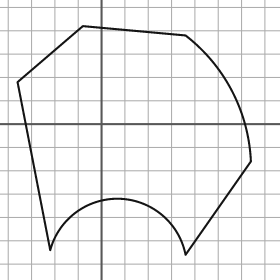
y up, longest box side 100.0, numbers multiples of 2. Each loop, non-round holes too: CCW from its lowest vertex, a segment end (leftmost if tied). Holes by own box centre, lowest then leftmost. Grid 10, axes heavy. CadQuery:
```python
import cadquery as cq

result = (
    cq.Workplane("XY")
    .moveTo(36.0, -56.0)
    .lineTo(64.0, -16.0)
    .threePointArc((56.0, 14.0), (36.0, 38.0))
    .lineTo(-8.0, 42.0)
    .lineTo(-36.0, 18.0)
    .lineTo(-22.0, -54.0)
    .threePointArc((8.0, -32.0), (36.0, -56.0))
    .close()
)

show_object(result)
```